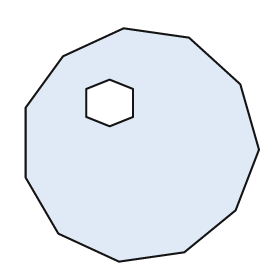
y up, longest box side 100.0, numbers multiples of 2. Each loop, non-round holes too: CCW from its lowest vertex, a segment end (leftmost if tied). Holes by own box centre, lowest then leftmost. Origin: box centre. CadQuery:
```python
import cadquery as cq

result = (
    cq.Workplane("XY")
    .moveTo(-10.0, -50.0)
    .lineTo(18.0, -46.0)
    .lineTo(40.0, -28.0)
    .lineTo(50.0, -2.0)
    .lineTo(42.0, 26.0)
    .lineTo(20.0, 46.0)
    .lineTo(-8.0, 50.0)
    .lineTo(-34.0, 38.0)
    .lineTo(-50.0, 16.0)
    .lineTo(-50.0, -14.0)
    .lineTo(-36.0, -38.0)
    .close()
    .moveTo(-14.0, 8.0)
    .lineTo(-4.0, 12.0)
    .lineTo(-4.0, 24.0)
    .lineTo(-14.0, 28.0)
    .lineTo(-24.0, 24.0)
    .lineTo(-24.0, 12.0)
    .close()
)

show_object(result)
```